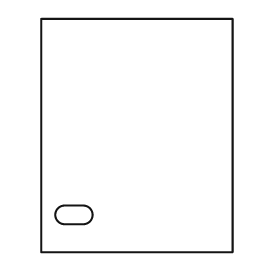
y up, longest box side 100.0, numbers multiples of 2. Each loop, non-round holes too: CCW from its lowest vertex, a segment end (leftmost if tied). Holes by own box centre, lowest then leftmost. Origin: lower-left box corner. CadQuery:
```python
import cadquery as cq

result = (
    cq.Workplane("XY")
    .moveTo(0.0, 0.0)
    .lineTo(82.0, 0.0)
    .lineTo(82.0, 100.0)
    .lineTo(0.0, 100.0)
    .close()
    .moveTo(10.0, 12.0)
    .lineTo(18.0, 12.0)
    .threePointArc((22.0, 16.0), (18.0, 20.0))
    .lineTo(10.0, 20.0)
    .threePointArc((6.0, 16.0), (10.0, 12.0))
    .close()
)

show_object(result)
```